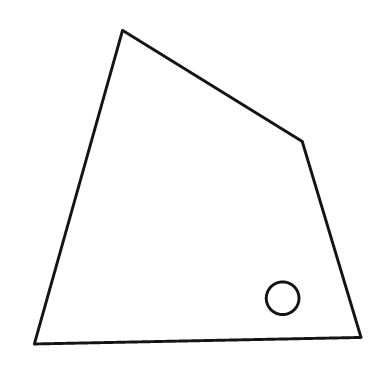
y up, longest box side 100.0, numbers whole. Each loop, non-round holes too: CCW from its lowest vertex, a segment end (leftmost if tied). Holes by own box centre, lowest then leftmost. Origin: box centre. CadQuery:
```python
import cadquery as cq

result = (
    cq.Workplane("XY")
    .moveTo(-50.0, -48.0)
    .lineTo(50.0, -46.0)
    .lineTo(32.0, 14.0)
    .lineTo(-23.0, 48.0)
    .close()
    .moveTo(26.0, -34.0)
    .circle(5.0)
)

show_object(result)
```